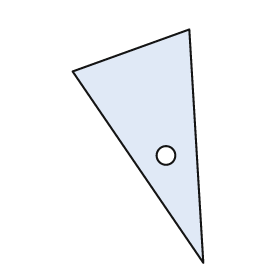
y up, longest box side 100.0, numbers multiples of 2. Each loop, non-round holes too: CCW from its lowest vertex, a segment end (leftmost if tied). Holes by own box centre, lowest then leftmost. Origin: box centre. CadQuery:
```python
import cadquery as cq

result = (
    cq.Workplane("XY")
    .moveTo(28.0, -50.0)
    .lineTo(22.0, 50.0)
    .lineTo(-28.0, 32.0)
    .close()
    .moveTo(12.0, -4.0)
    .circle(4.0)
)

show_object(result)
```